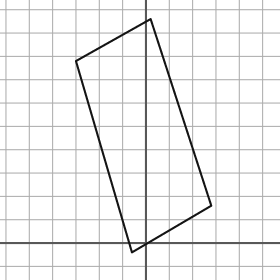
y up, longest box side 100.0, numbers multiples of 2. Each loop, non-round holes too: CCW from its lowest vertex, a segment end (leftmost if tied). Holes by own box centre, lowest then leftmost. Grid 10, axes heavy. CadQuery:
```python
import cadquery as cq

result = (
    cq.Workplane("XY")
    .moveTo(-6.0, -4.0)
    .lineTo(28.0, 16.0)
    .lineTo(2.0, 96.0)
    .lineTo(-30.0, 78.0)
    .close()
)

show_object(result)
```